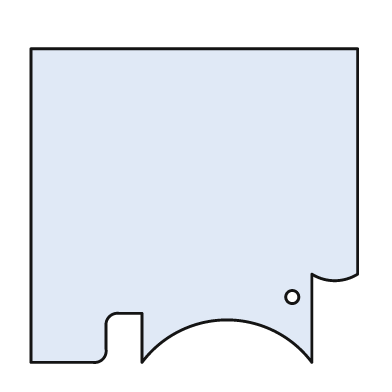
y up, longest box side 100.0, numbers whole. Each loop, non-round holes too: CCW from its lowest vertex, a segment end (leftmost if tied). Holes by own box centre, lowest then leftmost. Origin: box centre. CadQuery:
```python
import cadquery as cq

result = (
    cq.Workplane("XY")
    .moveTo(-50.0, -48.0)
    .lineTo(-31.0, -48.0)
    .threePointArc((-28.0, -47.0), (-27.0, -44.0))
    .lineTo(-27.0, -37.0)
    .threePointArc((-26.0, -34.0), (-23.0, -33.0))
    .lineTo(-16.0, -33.0)
    .lineTo(-16.0, -48.0)
    .threePointArc((10.0, -35.0), (36.0, -48.0))
    .lineTo(36.0, -21.0)
    .threePointArc((43.0, -23.0), (50.0, -21.0))
    .lineTo(50.0, 48.0)
    .lineTo(-50.0, 48.0)
    .close()
    .moveTo(30.0, -28.0)
    .circle(2.0)
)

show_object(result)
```